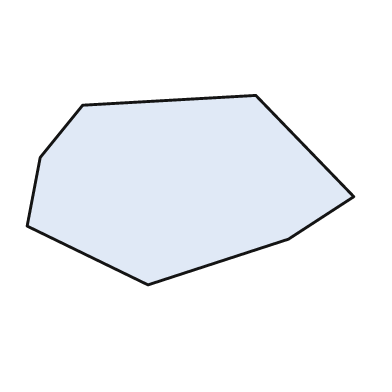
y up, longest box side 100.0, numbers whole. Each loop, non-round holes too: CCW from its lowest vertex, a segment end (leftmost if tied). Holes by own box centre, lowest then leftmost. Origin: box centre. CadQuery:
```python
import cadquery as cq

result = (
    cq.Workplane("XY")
    .moveTo(-13.0, -29.0)
    .lineTo(30.0, -15.0)
    .lineTo(50.0, -2.0)
    .lineTo(20.0, 29.0)
    .lineTo(-33.0, 26.0)
    .lineTo(-46.0, 10.0)
    .lineTo(-50.0, -11.0)
    .close()
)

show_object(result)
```